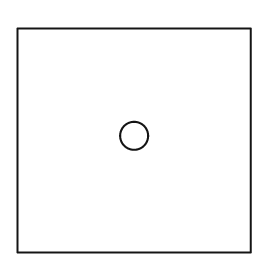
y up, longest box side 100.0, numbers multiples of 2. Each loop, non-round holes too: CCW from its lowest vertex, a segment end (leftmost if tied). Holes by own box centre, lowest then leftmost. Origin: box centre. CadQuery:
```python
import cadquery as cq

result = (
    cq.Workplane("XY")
    .moveTo(-50.0, -48.0)
    .lineTo(50.0, -48.0)
    .lineTo(50.0, 48.0)
    .lineTo(-50.0, 48.0)
    .close()
    .moveTo(0.0, 2.0)
    .circle(6.0)
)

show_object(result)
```